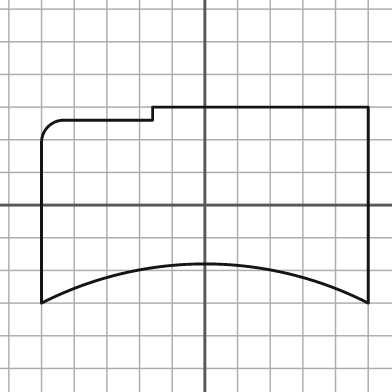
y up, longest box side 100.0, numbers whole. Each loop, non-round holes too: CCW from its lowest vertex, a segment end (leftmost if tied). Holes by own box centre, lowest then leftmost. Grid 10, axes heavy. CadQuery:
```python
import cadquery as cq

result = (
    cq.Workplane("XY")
    .moveTo(-50.0, -30.0)
    .threePointArc((0.0, -18.0), (50.0, -30.0))
    .lineTo(50.0, 30.0)
    .lineTo(-16.0, 30.0)
    .lineTo(-16.0, 26.0)
    .lineTo(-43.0, 26.0)
    .threePointArc((-48.0, 24.0), (-50.0, 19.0))
    .close()
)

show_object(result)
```